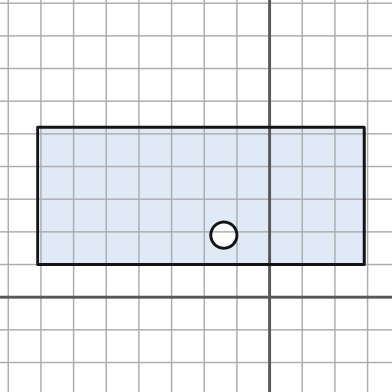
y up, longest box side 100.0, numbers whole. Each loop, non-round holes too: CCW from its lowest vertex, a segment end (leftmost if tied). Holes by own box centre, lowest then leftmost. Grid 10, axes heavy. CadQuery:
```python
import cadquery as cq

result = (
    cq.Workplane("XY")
    .moveTo(-71.0, 10.0)
    .lineTo(29.0, 10.0)
    .lineTo(29.0, 52.0)
    .lineTo(-71.0, 52.0)
    .close()
    .moveTo(-14.0, 19.0)
    .circle(4.0)
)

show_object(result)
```